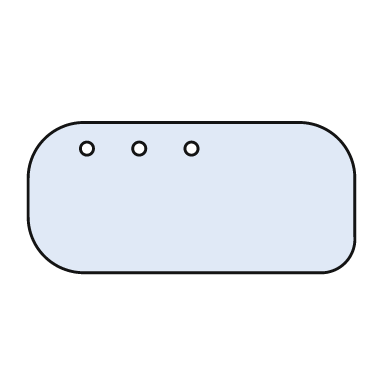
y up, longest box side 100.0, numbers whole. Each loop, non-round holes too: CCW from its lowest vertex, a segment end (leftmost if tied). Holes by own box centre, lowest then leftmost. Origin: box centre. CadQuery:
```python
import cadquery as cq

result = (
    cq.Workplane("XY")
    .moveTo(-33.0, -23.0)
    .lineTo(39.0, -23.0)
    .threePointArc((47.0, -20.0), (50.0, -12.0))
    .lineTo(50.0, 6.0)
    .threePointArc((45.0, 18.0), (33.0, 23.0))
    .lineTo(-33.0, 23.0)
    .threePointArc((-45.0, 18.0), (-50.0, 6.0))
    .lineTo(-50.0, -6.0)
    .threePointArc((-45.0, -18.0), (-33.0, -23.0))
    .close()
    .moveTo(-32.0, 15.0)
    .circle(2.0)
    .moveTo(-16.0, 15.0)
    .circle(2.0)
    .moveTo(0.0, 15.0)
    .circle(2.0)
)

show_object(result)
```